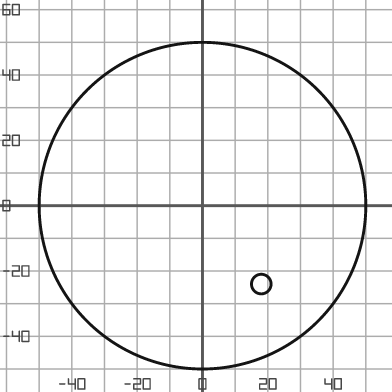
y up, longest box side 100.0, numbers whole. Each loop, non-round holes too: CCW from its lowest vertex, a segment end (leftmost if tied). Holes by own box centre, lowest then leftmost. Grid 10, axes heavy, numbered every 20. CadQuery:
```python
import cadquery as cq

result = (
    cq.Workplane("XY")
    .moveTo(0.0, 0.0)
    .circle(50.0)
    .moveTo(18.0, -24.0)
    .circle(3.0)
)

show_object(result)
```